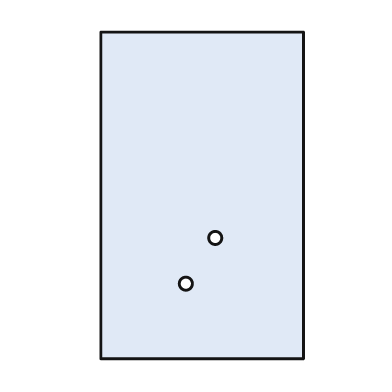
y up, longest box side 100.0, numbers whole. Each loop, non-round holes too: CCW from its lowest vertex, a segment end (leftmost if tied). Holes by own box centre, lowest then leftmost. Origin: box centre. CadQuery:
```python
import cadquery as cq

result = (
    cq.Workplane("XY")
    .moveTo(-31.0, -50.0)
    .lineTo(31.0, -50.0)
    .lineTo(31.0, 50.0)
    .lineTo(-31.0, 50.0)
    .close()
    .moveTo(-5.0, -27.0)
    .circle(2.0)
    .moveTo(4.0, -13.0)
    .circle(2.0)
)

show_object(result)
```